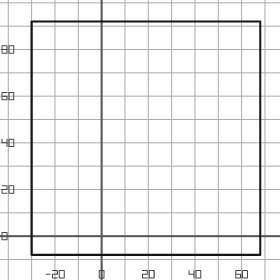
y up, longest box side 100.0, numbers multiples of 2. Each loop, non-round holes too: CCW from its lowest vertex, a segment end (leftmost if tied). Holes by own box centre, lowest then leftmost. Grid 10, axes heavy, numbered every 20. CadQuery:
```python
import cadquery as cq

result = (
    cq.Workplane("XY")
    .moveTo(-30.0, -8.0)
    .lineTo(68.0, -8.0)
    .lineTo(68.0, 92.0)
    .lineTo(-30.0, 92.0)
    .close()
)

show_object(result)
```